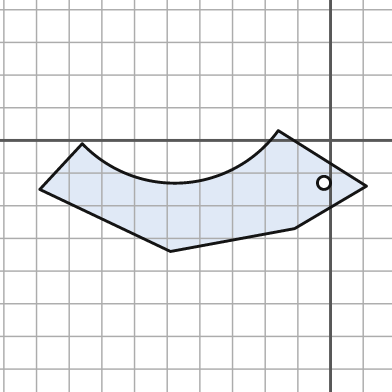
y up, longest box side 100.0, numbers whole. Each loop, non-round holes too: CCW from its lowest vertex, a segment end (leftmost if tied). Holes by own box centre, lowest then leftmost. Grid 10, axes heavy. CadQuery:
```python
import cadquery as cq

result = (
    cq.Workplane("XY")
    .moveTo(-49.0, -34.0)
    .lineTo(-11.0, -27.0)
    .lineTo(11.0, -14.0)
    .lineTo(-16.0, 3.0)
    .threePointArc((-45.0, -13.0), (-76.0, -1.0))
    .lineTo(-89.0, -15.0)
    .close()
    .moveTo(-2.0, -13.0)
    .circle(2.0)
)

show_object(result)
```